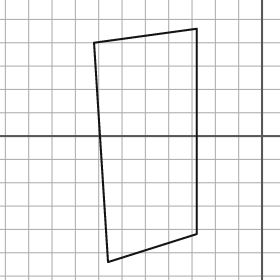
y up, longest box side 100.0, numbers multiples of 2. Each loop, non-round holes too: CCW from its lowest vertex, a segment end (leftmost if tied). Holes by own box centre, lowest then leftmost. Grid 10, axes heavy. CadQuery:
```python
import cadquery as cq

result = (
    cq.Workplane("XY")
    .moveTo(-66.0, -54.0)
    .lineTo(-28.0, -42.0)
    .lineTo(-28.0, 46.0)
    .lineTo(-72.0, 40.0)
    .close()
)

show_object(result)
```